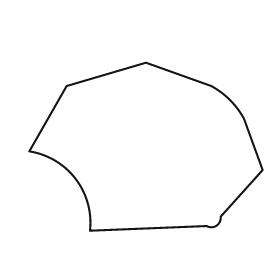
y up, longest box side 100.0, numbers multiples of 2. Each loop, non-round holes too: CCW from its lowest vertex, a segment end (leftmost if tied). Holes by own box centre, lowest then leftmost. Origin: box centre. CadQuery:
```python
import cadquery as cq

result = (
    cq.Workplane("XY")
    .moveTo(-24.0, -36.0)
    .lineTo(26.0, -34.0)
    .threePointArc((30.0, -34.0), (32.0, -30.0))
    .lineTo(50.0, -10.0)
    .lineTo(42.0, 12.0)
    .threePointArc((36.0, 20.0), (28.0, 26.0))
    .lineTo(0.0, 36.0)
    .lineTo(-34.0, 26.0)
    .lineTo(-50.0, -2.0)
    .threePointArc((-30.0, -14.0), (-24.0, -36.0))
    .close()
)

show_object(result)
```